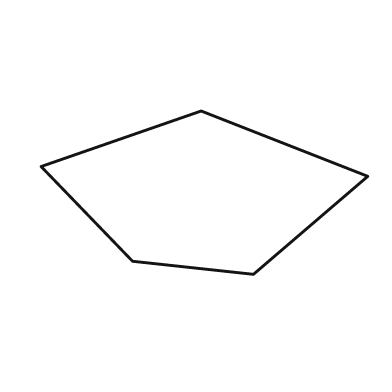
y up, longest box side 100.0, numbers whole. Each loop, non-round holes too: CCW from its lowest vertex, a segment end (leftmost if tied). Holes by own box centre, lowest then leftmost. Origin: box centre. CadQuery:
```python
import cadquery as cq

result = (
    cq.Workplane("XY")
    .moveTo(15.0, -25.0)
    .lineTo(50.0, 5.0)
    .lineTo(-1.0, 25.0)
    .lineTo(-50.0, 8.0)
    .lineTo(-22.0, -21.0)
    .close()
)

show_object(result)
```